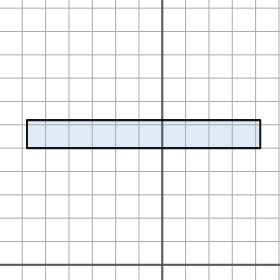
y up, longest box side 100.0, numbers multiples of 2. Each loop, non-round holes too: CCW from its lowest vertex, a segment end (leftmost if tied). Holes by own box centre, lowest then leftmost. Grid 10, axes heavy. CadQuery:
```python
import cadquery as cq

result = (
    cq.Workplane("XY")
    .moveTo(-58.0, 50.0)
    .lineTo(42.0, 50.0)
    .lineTo(42.0, 62.0)
    .lineTo(-58.0, 62.0)
    .close()
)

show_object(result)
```